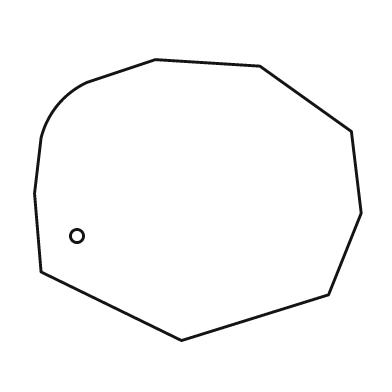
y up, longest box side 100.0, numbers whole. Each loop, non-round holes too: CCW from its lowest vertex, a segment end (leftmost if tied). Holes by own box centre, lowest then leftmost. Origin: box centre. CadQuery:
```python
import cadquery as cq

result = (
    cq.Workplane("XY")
    .moveTo(-5.0, -43.0)
    .lineTo(40.0, -29.0)
    .lineTo(50.0, -4.0)
    .lineTo(47.0, 21.0)
    .lineTo(19.0, 41.0)
    .lineTo(-13.0, 43.0)
    .lineTo(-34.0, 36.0)
    .threePointArc((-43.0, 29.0), (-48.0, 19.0))
    .lineTo(-50.0, 2.0)
    .lineTo(-48.0, -22.0)
    .close()
    .moveTo(-37.0, -11.0)
    .circle(2.0)
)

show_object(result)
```